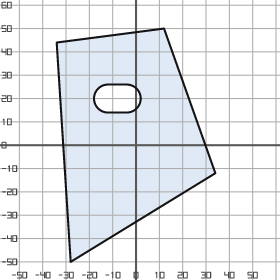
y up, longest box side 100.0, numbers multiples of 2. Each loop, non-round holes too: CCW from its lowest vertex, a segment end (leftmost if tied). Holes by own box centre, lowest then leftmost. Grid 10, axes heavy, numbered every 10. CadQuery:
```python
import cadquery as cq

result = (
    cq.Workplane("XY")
    .moveTo(-28.0, -50.0)
    .lineTo(34.0, -12.0)
    .lineTo(12.0, 50.0)
    .lineTo(-34.0, 44.0)
    .close()
    .moveTo(-12.0, 14.0)
    .lineTo(-4.0, 14.0)
    .threePointArc((2.0, 20.0), (-4.0, 26.0))
    .lineTo(-12.0, 26.0)
    .threePointArc((-18.0, 20.0), (-12.0, 14.0))
    .close()
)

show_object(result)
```